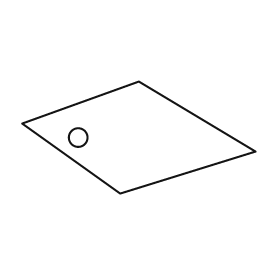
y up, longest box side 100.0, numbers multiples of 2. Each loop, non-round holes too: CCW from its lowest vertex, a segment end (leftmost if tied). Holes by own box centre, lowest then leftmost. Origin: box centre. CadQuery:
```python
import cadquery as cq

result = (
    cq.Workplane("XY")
    .moveTo(-8.0, -24.0)
    .lineTo(50.0, -6.0)
    .lineTo(0.0, 24.0)
    .lineTo(-50.0, 6.0)
    .close()
    .moveTo(-26.0, 0.0)
    .circle(4.0)
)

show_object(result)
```